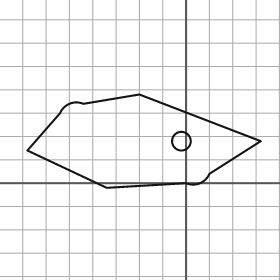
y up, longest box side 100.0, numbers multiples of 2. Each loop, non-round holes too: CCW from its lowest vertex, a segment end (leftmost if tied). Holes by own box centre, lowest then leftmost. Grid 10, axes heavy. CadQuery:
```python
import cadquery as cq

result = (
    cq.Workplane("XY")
    .moveTo(-34.0, -2.0)
    .lineTo(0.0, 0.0)
    .threePointArc((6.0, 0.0), (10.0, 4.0))
    .lineTo(32.0, 18.0)
    .lineTo(-20.0, 38.0)
    .lineTo(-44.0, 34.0)
    .threePointArc((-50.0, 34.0), (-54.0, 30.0))
    .lineTo(-68.0, 14.0)
    .close()
    .moveTo(-2.0, 18.0)
    .circle(4.0)
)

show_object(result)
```